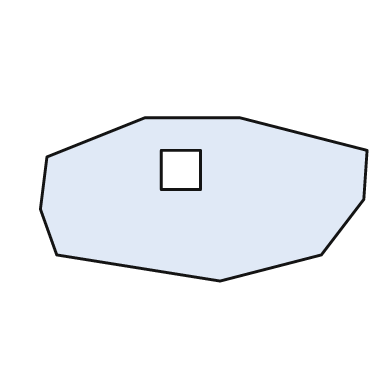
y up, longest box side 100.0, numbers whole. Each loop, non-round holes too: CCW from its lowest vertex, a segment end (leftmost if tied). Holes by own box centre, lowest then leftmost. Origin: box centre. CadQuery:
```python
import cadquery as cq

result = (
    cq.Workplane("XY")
    .moveTo(5.0, -25.0)
    .lineTo(36.0, -17.0)
    .lineTo(49.0, 0.0)
    .lineTo(50.0, 15.0)
    .lineTo(11.0, 25.0)
    .lineTo(-18.0, 25.0)
    .lineTo(-48.0, 13.0)
    .lineTo(-50.0, -3.0)
    .lineTo(-45.0, -17.0)
    .close()
    .moveTo(-13.0, 3.0)
    .lineTo(-1.0, 3.0)
    .lineTo(-1.0, 15.0)
    .lineTo(-13.0, 15.0)
    .close()
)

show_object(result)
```